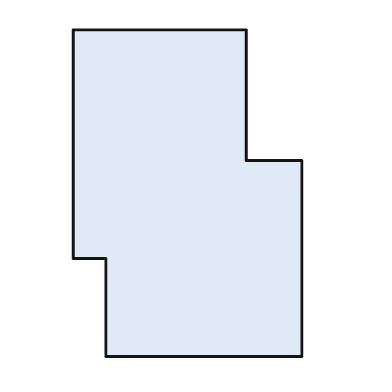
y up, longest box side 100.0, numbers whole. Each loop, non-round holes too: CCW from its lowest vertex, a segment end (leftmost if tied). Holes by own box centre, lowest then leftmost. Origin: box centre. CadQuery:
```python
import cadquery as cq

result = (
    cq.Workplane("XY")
    .moveTo(-25.0, -50.0)
    .lineTo(35.0, -50.0)
    .lineTo(35.0, 10.0)
    .lineTo(18.0, 10.0)
    .lineTo(18.0, 50.0)
    .lineTo(-35.0, 50.0)
    .lineTo(-35.0, -20.0)
    .lineTo(-25.0, -20.0)
    .close()
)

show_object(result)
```